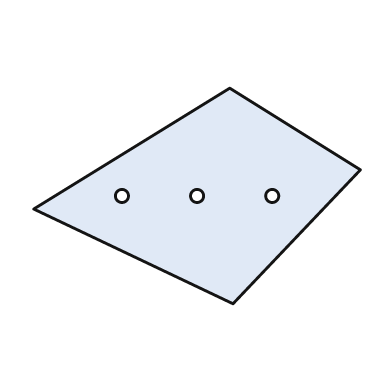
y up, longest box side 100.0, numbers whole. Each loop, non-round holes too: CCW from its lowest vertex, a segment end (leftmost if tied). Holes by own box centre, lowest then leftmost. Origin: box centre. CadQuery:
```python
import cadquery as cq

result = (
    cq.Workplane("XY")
    .moveTo(11.0, -33.0)
    .lineTo(50.0, 8.0)
    .lineTo(10.0, 33.0)
    .lineTo(-50.0, -4.0)
    .close()
    .moveTo(-23.0, 0.0)
    .circle(2.0)
    .moveTo(0.0, 0.0)
    .circle(2.0)
    .moveTo(23.0, 0.0)
    .circle(2.0)
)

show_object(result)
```